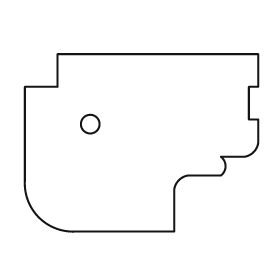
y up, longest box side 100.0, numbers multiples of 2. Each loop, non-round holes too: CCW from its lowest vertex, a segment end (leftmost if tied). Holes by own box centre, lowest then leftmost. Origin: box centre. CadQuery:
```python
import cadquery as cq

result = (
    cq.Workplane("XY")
    .moveTo(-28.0, -38.0)
    .lineTo(14.0, -38.0)
    .lineTo(14.0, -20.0)
    .threePointArc((16.0, -16.0), (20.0, -14.0))
    .lineTo(34.0, -14.0)
    .threePointArc((36.0, -10.0), (34.0, -6.0))
    .lineTo(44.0, -6.0)
    .threePointArc((48.0, -4.0), (50.0, 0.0))
    .lineTo(50.0, 10.0)
    .lineTo(46.0, 10.0)
    .lineTo(46.0, 24.0)
    .lineTo(50.0, 24.0)
    .lineTo(50.0, 38.0)
    .lineTo(-36.0, 38.0)
    .lineTo(-36.0, 24.0)
    .lineTo(-50.0, 24.0)
    .lineTo(-50.0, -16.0)
    .threePointArc((-44.0, -32.0), (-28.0, -38.0))
    .close()
    .moveTo(-22.0, 8.0)
    .circle(4.0)
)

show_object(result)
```